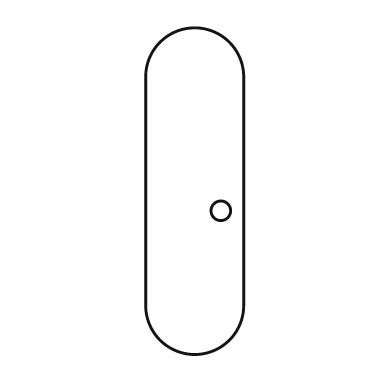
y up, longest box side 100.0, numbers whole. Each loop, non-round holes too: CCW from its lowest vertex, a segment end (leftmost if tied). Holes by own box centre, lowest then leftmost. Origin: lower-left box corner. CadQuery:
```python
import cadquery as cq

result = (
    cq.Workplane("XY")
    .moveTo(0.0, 15.0)
    .threePointArc((15.0, 0.0), (30.0, 15.0))
    .lineTo(30.0, 85.0)
    .threePointArc((15.0, 100.0), (0.0, 85.0))
    .close()
    .moveTo(23.0, 44.0)
    .circle(3.0)
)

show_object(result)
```